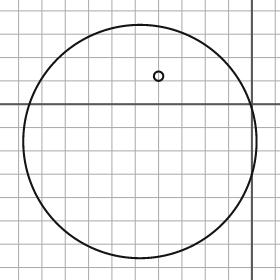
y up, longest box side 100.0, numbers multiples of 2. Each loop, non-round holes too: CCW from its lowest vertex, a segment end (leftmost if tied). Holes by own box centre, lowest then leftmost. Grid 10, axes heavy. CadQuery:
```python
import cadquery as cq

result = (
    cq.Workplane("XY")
    .moveTo(-48.0, -16.0)
    .circle(50.0)
    .moveTo(-40.0, 12.0)
    .circle(2.0)
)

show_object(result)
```